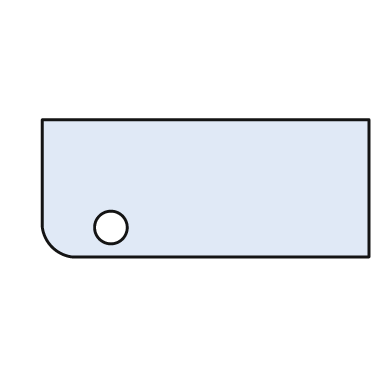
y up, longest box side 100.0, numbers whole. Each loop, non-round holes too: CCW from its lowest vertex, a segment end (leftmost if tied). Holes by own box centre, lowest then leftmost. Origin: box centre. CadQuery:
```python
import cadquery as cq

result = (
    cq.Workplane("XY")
    .moveTo(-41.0, -21.0)
    .lineTo(50.0, -21.0)
    .lineTo(50.0, 21.0)
    .lineTo(-50.0, 21.0)
    .lineTo(-50.0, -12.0)
    .threePointArc((-47.0, -18.0), (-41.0, -21.0))
    .close()
    .moveTo(-29.0, -12.0)
    .circle(5.0)
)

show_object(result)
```